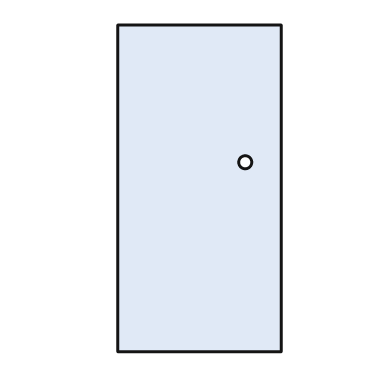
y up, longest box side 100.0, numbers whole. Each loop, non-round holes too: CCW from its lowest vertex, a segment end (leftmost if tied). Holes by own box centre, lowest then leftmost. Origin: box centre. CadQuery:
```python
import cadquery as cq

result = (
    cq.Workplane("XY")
    .moveTo(-25.0, -50.0)
    .lineTo(25.0, -50.0)
    .lineTo(25.0, 50.0)
    .lineTo(-25.0, 50.0)
    .close()
    .moveTo(14.0, 8.0)
    .circle(2.0)
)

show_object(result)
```